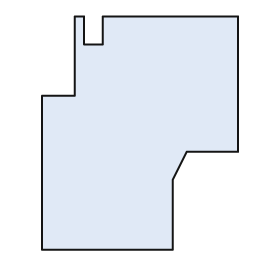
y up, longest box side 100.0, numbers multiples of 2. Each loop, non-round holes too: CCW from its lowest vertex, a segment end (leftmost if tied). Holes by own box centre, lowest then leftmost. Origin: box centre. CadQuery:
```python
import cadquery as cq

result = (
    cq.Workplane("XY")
    .moveTo(-42.0, -50.0)
    .lineTo(14.0, -50.0)
    .lineTo(14.0, -20.0)
    .lineTo(20.0, -8.0)
    .lineTo(42.0, -8.0)
    .lineTo(42.0, 50.0)
    .lineTo(-16.0, 50.0)
    .lineTo(-16.0, 38.0)
    .lineTo(-24.0, 38.0)
    .lineTo(-24.0, 50.0)
    .lineTo(-28.0, 50.0)
    .lineTo(-28.0, 16.0)
    .lineTo(-42.0, 16.0)
    .close()
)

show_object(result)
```